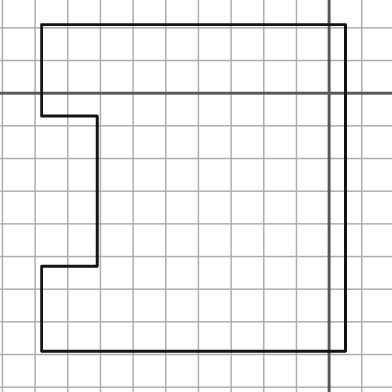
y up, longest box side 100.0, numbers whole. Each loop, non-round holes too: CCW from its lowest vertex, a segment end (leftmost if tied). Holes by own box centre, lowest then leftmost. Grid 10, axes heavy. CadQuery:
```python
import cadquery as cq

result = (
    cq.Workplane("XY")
    .moveTo(-88.0, -79.0)
    .lineTo(5.0, -79.0)
    .lineTo(5.0, 21.0)
    .lineTo(-88.0, 21.0)
    .lineTo(-88.0, -7.0)
    .lineTo(-71.0, -7.0)
    .lineTo(-71.0, -53.0)
    .lineTo(-88.0, -53.0)
    .close()
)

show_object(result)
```